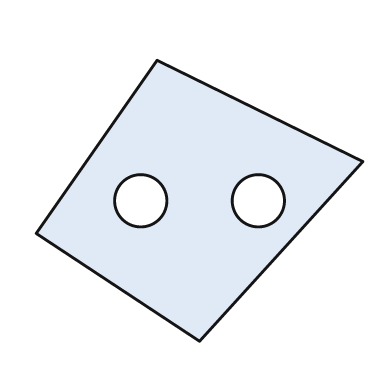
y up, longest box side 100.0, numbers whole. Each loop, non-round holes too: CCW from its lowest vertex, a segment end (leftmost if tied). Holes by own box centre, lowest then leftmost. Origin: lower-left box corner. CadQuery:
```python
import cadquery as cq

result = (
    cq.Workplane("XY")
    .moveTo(50.0, 0.0)
    .lineTo(100.0, 55.0)
    .lineTo(37.0, 86.0)
    .lineTo(0.0, 33.0)
    .close()
    .moveTo(32.0, 43.0)
    .circle(8.0)
    .moveTo(68.0, 43.0)
    .circle(8.0)
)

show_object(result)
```